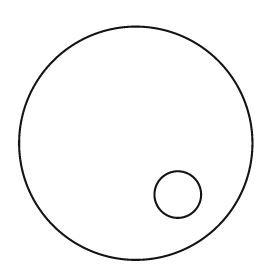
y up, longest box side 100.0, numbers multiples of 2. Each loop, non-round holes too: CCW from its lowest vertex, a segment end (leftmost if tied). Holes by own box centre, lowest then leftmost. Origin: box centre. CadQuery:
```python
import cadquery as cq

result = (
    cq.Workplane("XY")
    .moveTo(0.0, 0.0)
    .circle(50.0)
    .moveTo(18.0, -22.0)
    .circle(10.0)
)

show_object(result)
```